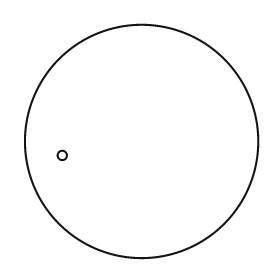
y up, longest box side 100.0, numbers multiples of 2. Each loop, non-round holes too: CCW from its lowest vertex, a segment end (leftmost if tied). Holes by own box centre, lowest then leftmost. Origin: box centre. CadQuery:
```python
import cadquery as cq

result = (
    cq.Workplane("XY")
    .moveTo(0.0, 0.0)
    .circle(50.0)
    .moveTo(-34.0, -6.0)
    .circle(2.0)
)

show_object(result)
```